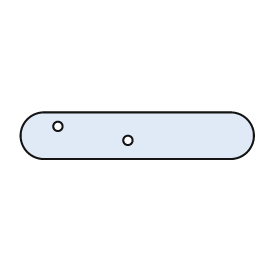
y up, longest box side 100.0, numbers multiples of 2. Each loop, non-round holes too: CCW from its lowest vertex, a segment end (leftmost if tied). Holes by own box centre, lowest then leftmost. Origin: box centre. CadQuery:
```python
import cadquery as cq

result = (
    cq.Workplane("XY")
    .moveTo(-40.0, -10.0)
    .lineTo(40.0, -10.0)
    .threePointArc((50.0, 0.0), (40.0, 10.0))
    .lineTo(-40.0, 10.0)
    .threePointArc((-50.0, 0.0), (-40.0, -10.0))
    .close()
    .moveTo(-4.0, -2.0)
    .circle(2.0)
    .moveTo(-34.0, 4.0)
    .circle(2.0)
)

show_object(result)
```